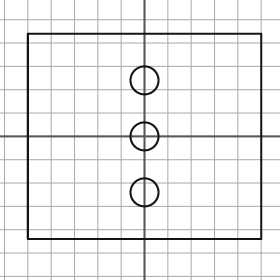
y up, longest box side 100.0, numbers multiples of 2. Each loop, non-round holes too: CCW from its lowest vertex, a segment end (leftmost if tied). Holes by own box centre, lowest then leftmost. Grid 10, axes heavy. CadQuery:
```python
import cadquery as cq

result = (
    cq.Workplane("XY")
    .moveTo(-50.0, -44.0)
    .lineTo(50.0, -44.0)
    .lineTo(50.0, 44.0)
    .lineTo(-50.0, 44.0)
    .close()
    .moveTo(0.0, -24.0)
    .circle(6.0)
    .moveTo(0.0, 0.0)
    .circle(6.0)
    .moveTo(0.0, 24.0)
    .circle(6.0)
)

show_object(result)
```